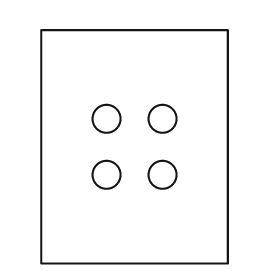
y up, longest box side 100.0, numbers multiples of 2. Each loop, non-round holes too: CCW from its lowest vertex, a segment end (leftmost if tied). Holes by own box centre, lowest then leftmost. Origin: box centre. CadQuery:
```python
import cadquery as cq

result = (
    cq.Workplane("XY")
    .moveTo(-40.0, -50.0)
    .lineTo(40.0, -50.0)
    .lineTo(40.0, 50.0)
    .lineTo(-40.0, 50.0)
    .close()
    .moveTo(-12.0, -12.0)
    .circle(6.0)
    .moveTo(12.0, -12.0)
    .circle(6.0)
    .moveTo(-12.0, 12.0)
    .circle(6.0)
    .moveTo(12.0, 12.0)
    .circle(6.0)
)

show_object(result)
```